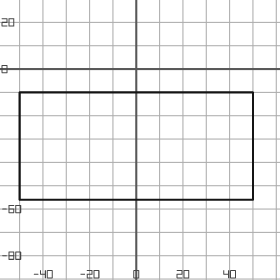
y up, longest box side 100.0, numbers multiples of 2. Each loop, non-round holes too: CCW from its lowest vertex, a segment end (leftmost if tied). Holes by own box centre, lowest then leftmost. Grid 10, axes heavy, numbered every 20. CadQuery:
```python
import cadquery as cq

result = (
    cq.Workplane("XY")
    .moveTo(-50.0, -56.0)
    .lineTo(50.0, -56.0)
    .lineTo(50.0, -10.0)
    .lineTo(-50.0, -10.0)
    .close()
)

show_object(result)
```